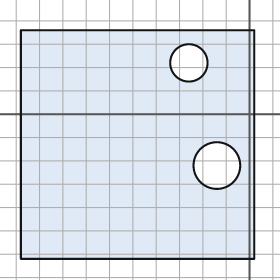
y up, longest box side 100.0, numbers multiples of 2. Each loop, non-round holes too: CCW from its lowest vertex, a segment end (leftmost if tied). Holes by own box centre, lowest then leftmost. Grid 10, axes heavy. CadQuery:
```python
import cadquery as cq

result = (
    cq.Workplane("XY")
    .moveTo(-98.0, -62.0)
    .lineTo(2.0, -62.0)
    .lineTo(2.0, 36.0)
    .lineTo(-98.0, 36.0)
    .close()
    .moveTo(-14.0, -22.0)
    .circle(10.0)
    .moveTo(-26.0, 22.0)
    .circle(8.0)
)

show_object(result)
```